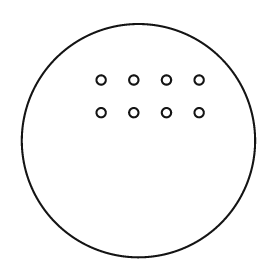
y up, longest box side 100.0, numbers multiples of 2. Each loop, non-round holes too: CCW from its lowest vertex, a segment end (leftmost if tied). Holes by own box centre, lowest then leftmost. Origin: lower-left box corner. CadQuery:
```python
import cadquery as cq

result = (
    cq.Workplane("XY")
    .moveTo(50.0, 50.0)
    .circle(50.0)
    .moveTo(34.0, 62.0)
    .circle(2.0)
    .moveTo(48.0, 62.0)
    .circle(2.0)
    .moveTo(62.0, 62.0)
    .circle(2.0)
    .moveTo(76.0, 62.0)
    .circle(2.0)
    .moveTo(34.0, 76.0)
    .circle(2.0)
    .moveTo(48.0, 76.0)
    .circle(2.0)
    .moveTo(62.0, 76.0)
    .circle(2.0)
    .moveTo(76.0, 76.0)
    .circle(2.0)
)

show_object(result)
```